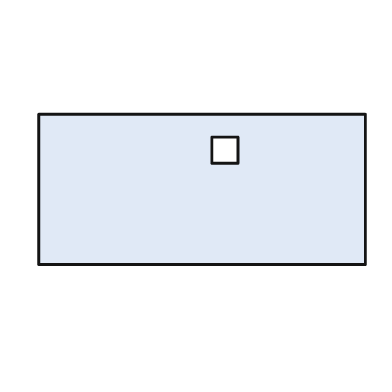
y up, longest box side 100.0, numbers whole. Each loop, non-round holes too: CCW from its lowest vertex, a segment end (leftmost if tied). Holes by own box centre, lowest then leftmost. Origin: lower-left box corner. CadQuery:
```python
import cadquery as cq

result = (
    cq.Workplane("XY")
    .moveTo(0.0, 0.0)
    .lineTo(100.0, 0.0)
    .lineTo(100.0, 46.0)
    .lineTo(0.0, 46.0)
    .close()
    .moveTo(53.0, 31.0)
    .lineTo(61.0, 31.0)
    .lineTo(61.0, 39.0)
    .lineTo(53.0, 39.0)
    .close()
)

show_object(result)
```